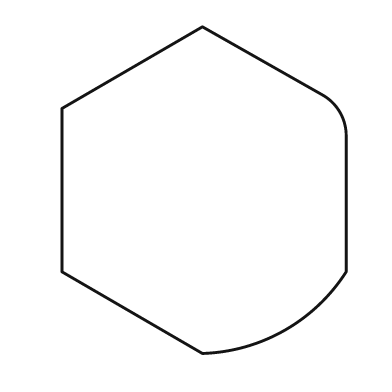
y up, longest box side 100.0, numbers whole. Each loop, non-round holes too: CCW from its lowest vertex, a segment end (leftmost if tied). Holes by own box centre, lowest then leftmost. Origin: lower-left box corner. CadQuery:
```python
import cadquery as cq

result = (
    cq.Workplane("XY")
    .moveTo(43.0, 0.0)
    .threePointArc((68.0, 7.0), (87.0, 25.0))
    .lineTo(87.0, 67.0)
    .threePointArc((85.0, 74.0), (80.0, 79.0))
    .lineTo(43.0, 100.0)
    .lineTo(0.0, 75.0)
    .lineTo(0.0, 25.0)
    .close()
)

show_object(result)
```